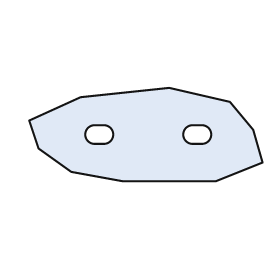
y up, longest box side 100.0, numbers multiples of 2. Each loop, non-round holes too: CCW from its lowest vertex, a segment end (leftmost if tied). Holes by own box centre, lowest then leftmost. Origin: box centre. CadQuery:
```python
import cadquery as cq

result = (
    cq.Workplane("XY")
    .moveTo(-10.0, -20.0)
    .lineTo(30.0, -20.0)
    .lineTo(50.0, -12.0)
    .lineTo(46.0, 2.0)
    .lineTo(36.0, 14.0)
    .lineTo(10.0, 20.0)
    .lineTo(-28.0, 16.0)
    .lineTo(-50.0, 6.0)
    .lineTo(-46.0, -6.0)
    .lineTo(-32.0, -16.0)
    .close()
    .moveTo(-22.0, -4.0)
    .lineTo(-18.0, -4.0)
    .threePointArc((-14.0, 0.0), (-18.0, 4.0))
    .lineTo(-22.0, 4.0)
    .threePointArc((-26.0, 0.0), (-22.0, -4.0))
    .close()
    .moveTo(20.0, -4.0)
    .lineTo(24.0, -4.0)
    .threePointArc((28.0, 0.0), (24.0, 4.0))
    .lineTo(20.0, 4.0)
    .threePointArc((16.0, 0.0), (20.0, -4.0))
    .close()
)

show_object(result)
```